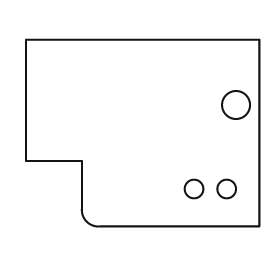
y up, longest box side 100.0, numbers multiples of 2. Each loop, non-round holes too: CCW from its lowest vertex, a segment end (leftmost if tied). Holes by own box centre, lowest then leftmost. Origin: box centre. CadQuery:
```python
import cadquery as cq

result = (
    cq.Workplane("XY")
    .moveTo(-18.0, -40.0)
    .lineTo(50.0, -40.0)
    .lineTo(50.0, 40.0)
    .lineTo(-50.0, 40.0)
    .lineTo(-50.0, -12.0)
    .lineTo(-26.0, -12.0)
    .lineTo(-26.0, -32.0)
    .threePointArc((-24.0, -38.0), (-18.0, -40.0))
    .close()
    .moveTo(22.0, -24.0)
    .circle(4.0)
    .moveTo(36.0, -24.0)
    .circle(4.0)
    .moveTo(40.0, 12.0)
    .circle(6.0)
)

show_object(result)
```